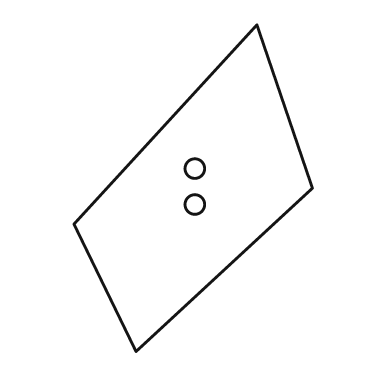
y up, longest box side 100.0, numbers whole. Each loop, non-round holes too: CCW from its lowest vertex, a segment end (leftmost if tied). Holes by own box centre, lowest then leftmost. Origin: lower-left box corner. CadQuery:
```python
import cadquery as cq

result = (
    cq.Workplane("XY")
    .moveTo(19.0, 0.0)
    .lineTo(73.0, 50.0)
    .lineTo(56.0, 100.0)
    .lineTo(0.0, 39.0)
    .close()
    .moveTo(37.0, 45.0)
    .circle(3.0)
    .moveTo(37.0, 56.0)
    .circle(3.0)
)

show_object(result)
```